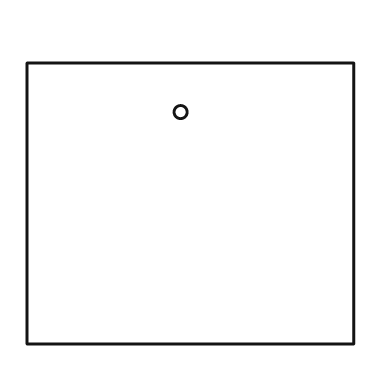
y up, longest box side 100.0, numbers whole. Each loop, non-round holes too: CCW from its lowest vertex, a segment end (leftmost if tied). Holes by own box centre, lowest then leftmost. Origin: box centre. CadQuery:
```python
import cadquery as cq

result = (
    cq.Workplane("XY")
    .moveTo(-50.0, -43.0)
    .lineTo(50.0, -43.0)
    .lineTo(50.0, 43.0)
    .lineTo(-50.0, 43.0)
    .close()
    .moveTo(-3.0, 28.0)
    .circle(2.0)
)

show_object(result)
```